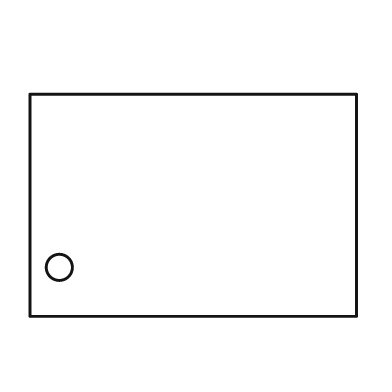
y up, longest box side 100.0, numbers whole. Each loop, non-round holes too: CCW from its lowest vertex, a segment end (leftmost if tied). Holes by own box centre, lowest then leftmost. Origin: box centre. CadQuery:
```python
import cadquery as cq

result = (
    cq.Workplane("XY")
    .moveTo(-50.0, -34.0)
    .lineTo(50.0, -34.0)
    .lineTo(50.0, 34.0)
    .lineTo(-50.0, 34.0)
    .close()
    .moveTo(-41.0, -19.0)
    .circle(4.0)
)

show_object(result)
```